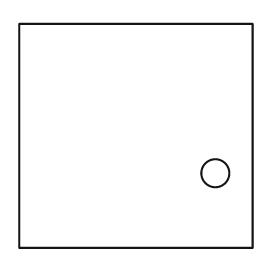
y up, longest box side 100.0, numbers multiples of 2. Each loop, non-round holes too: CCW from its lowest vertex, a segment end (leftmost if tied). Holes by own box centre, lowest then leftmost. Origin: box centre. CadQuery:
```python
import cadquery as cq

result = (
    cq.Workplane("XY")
    .moveTo(-50.0, -48.0)
    .lineTo(50.0, -48.0)
    .lineTo(50.0, 48.0)
    .lineTo(-50.0, 48.0)
    .close()
    .moveTo(34.0, -16.0)
    .circle(6.0)
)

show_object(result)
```